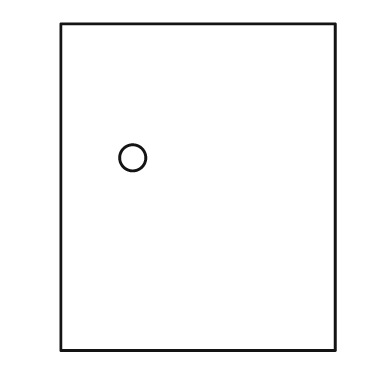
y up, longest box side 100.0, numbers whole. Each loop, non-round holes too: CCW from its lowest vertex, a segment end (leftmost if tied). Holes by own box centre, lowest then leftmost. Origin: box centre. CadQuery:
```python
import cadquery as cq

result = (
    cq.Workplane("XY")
    .moveTo(-42.0, -50.0)
    .lineTo(42.0, -50.0)
    .lineTo(42.0, 50.0)
    .lineTo(-42.0, 50.0)
    .close()
    .moveTo(-20.0, 9.0)
    .circle(4.0)
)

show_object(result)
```